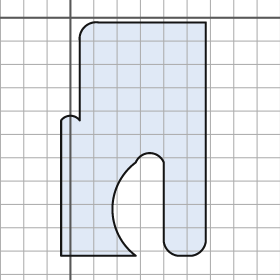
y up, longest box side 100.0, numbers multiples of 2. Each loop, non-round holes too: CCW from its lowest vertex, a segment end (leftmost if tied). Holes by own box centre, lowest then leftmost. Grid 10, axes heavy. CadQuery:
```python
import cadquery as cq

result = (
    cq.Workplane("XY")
    .moveTo(-4.0, -102.0)
    .lineTo(28.0, -102.0)
    .threePointArc((18.0, -82.0), (28.0, -62.0))
    .threePointArc((34.0, -58.0), (40.0, -62.0))
    .lineTo(40.0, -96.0)
    .threePointArc((42.0, -100.0), (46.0, -102.0))
    .lineTo(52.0, -102.0)
    .threePointArc((56.0, -100.0), (58.0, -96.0))
    .lineTo(58.0, -2.0)
    .lineTo(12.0, -2.0)
    .threePointArc((6.0, -4.0), (4.0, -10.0))
    .lineTo(4.0, -44.0)
    .threePointArc((0.0, -42.0), (-4.0, -44.0))
    .close()
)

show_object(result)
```